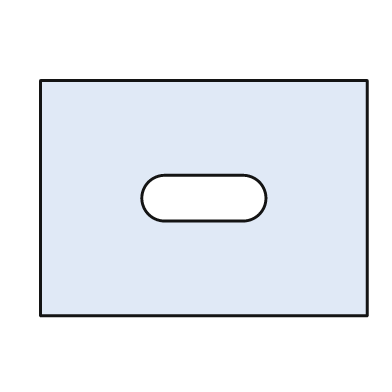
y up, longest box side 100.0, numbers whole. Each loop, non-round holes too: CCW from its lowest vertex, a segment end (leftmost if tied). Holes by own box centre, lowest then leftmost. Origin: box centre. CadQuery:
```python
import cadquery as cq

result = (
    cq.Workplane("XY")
    .moveTo(-50.0, -36.0)
    .lineTo(50.0, -36.0)
    .lineTo(50.0, 36.0)
    .lineTo(-50.0, 36.0)
    .close()
    .moveTo(-12.0, -7.0)
    .lineTo(12.0, -7.0)
    .threePointArc((19.0, 0.0), (12.0, 7.0))
    .lineTo(-12.0, 7.0)
    .threePointArc((-19.0, 0.0), (-12.0, -7.0))
    .close()
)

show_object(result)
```